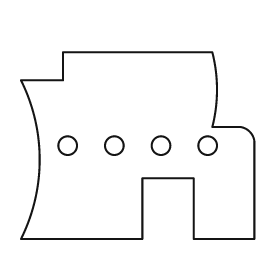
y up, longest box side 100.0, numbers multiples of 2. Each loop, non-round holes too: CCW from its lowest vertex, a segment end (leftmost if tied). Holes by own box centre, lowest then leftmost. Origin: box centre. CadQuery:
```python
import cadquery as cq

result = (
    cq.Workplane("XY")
    .moveTo(-50.0, -40.0)
    .lineTo(2.0, -40.0)
    .lineTo(2.0, -14.0)
    .lineTo(24.0, -14.0)
    .lineTo(24.0, -40.0)
    .lineTo(50.0, -40.0)
    .lineTo(50.0, 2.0)
    .threePointArc((48.0, 6.0), (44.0, 8.0))
    .lineTo(32.0, 8.0)
    .threePointArc((34.0, 24.0), (32.0, 40.0))
    .lineTo(-32.0, 40.0)
    .lineTo(-32.0, 28.0)
    .lineTo(-50.0, 28.0)
    .threePointArc((-42.0, -6.0), (-50.0, -40.0))
    .close()
    .moveTo(-30.0, 0.0)
    .circle(4.0)
    .moveTo(-10.0, 0.0)
    .circle(4.0)
    .moveTo(10.0, 0.0)
    .circle(4.0)
    .moveTo(30.0, 0.0)
    .circle(4.0)
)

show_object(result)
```